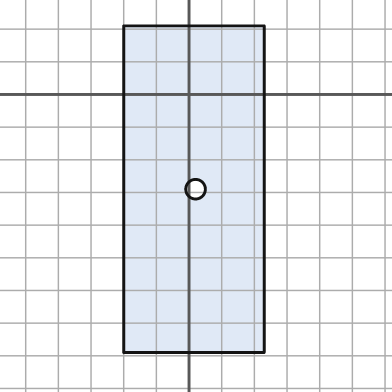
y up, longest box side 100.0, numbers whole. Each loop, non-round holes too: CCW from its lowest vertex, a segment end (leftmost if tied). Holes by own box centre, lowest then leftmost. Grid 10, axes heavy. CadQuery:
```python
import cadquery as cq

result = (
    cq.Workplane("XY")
    .moveTo(-20.0, -79.0)
    .lineTo(23.0, -79.0)
    .lineTo(23.0, 21.0)
    .lineTo(-20.0, 21.0)
    .close()
    .moveTo(2.0, -29.0)
    .circle(3.0)
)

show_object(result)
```